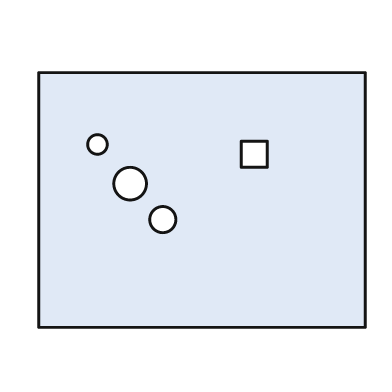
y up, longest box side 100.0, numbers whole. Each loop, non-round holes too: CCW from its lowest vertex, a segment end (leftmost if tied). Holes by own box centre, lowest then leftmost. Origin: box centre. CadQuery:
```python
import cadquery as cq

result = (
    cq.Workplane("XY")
    .moveTo(-50.0, -39.0)
    .lineTo(50.0, -39.0)
    .lineTo(50.0, 39.0)
    .lineTo(-50.0, 39.0)
    .close()
    .moveTo(-12.0, -6.0)
    .circle(4.0)
    .moveTo(-22.0, 5.0)
    .circle(5.0)
    .moveTo(12.0, 10.0)
    .lineTo(20.0, 10.0)
    .lineTo(20.0, 18.0)
    .lineTo(12.0, 18.0)
    .close()
    .moveTo(-32.0, 17.0)
    .circle(3.0)
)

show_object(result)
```